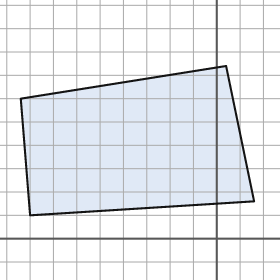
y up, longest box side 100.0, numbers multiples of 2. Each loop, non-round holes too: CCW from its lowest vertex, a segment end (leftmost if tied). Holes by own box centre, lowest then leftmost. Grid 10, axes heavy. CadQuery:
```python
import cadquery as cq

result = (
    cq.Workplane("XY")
    .moveTo(-80.0, 10.0)
    .lineTo(16.0, 16.0)
    .lineTo(4.0, 74.0)
    .lineTo(-84.0, 60.0)
    .close()
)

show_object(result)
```